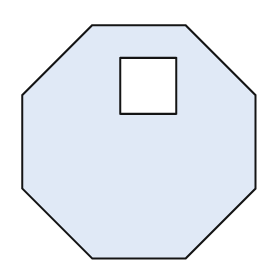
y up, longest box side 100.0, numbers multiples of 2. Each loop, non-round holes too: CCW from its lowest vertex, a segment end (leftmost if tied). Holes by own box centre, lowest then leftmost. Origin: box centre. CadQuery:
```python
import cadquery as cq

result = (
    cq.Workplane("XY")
    .moveTo(-20.0, -50.0)
    .lineTo(20.0, -50.0)
    .lineTo(50.0, -20.0)
    .lineTo(50.0, 20.0)
    .lineTo(20.0, 50.0)
    .lineTo(-20.0, 50.0)
    .lineTo(-50.0, 20.0)
    .lineTo(-50.0, -20.0)
    .close()
    .moveTo(-8.0, 12.0)
    .lineTo(16.0, 12.0)
    .lineTo(16.0, 36.0)
    .lineTo(-8.0, 36.0)
    .close()
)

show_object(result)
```